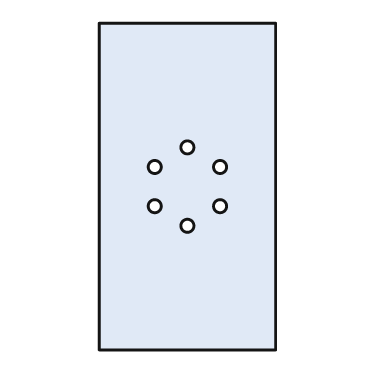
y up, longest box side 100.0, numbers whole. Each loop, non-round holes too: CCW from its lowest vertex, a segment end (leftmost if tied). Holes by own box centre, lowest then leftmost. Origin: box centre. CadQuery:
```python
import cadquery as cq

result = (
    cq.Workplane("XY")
    .moveTo(-27.0, -50.0)
    .lineTo(27.0, -50.0)
    .lineTo(27.0, 50.0)
    .lineTo(-27.0, 50.0)
    .close()
    .moveTo(0.0, -12.0)
    .circle(2.0)
    .moveTo(-10.0, -6.0)
    .circle(2.0)
    .moveTo(10.0, -6.0)
    .circle(2.0)
    .moveTo(-10.0, 6.0)
    .circle(2.0)
    .moveTo(10.0, 6.0)
    .circle(2.0)
    .moveTo(0.0, 12.0)
    .circle(2.0)
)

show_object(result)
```